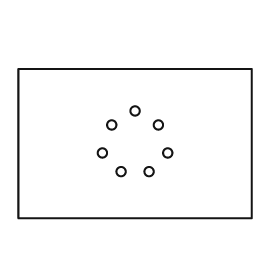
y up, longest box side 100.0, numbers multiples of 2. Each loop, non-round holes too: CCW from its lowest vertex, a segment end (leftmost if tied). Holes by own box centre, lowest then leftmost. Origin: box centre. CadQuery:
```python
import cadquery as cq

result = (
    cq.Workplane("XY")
    .moveTo(-50.0, -32.0)
    .lineTo(50.0, -32.0)
    .lineTo(50.0, 32.0)
    .lineTo(-50.0, 32.0)
    .close()
    .moveTo(-6.0, -12.0)
    .circle(2.0)
    .moveTo(6.0, -12.0)
    .circle(2.0)
    .moveTo(-14.0, -4.0)
    .circle(2.0)
    .moveTo(14.0, -4.0)
    .circle(2.0)
    .moveTo(-10.0, 8.0)
    .circle(2.0)
    .moveTo(10.0, 8.0)
    .circle(2.0)
    .moveTo(0.0, 14.0)
    .circle(2.0)
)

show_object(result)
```